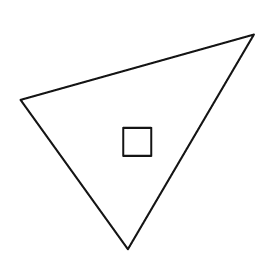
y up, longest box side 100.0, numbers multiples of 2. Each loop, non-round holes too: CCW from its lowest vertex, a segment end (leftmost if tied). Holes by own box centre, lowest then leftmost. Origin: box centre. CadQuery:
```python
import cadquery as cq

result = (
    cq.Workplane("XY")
    .moveTo(-4.0, -46.0)
    .lineTo(50.0, 46.0)
    .lineTo(-50.0, 18.0)
    .close()
    .moveTo(-6.0, -6.0)
    .lineTo(6.0, -6.0)
    .lineTo(6.0, 6.0)
    .lineTo(-6.0, 6.0)
    .close()
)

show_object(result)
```